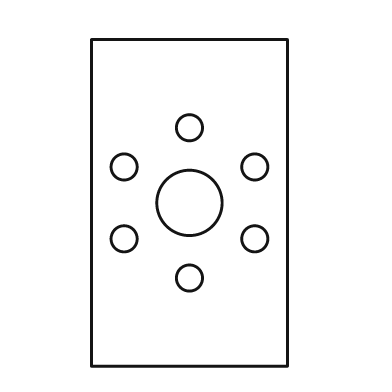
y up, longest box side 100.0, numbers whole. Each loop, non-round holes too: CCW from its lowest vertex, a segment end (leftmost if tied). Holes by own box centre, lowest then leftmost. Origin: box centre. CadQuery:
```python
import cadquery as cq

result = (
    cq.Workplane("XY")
    .moveTo(-30.0, -50.0)
    .lineTo(30.0, -50.0)
    .lineTo(30.0, 50.0)
    .lineTo(-30.0, 50.0)
    .close()
    .moveTo(0.0, -23.0)
    .circle(4.0)
    .moveTo(-20.0, -11.0)
    .circle(4.0)
    .moveTo(20.0, -11.0)
    .circle(4.0)
    .moveTo(0.0, 0.0)
    .circle(10.0)
    .moveTo(-20.0, 11.0)
    .circle(4.0)
    .moveTo(20.0, 11.0)
    .circle(4.0)
    .moveTo(0.0, 23.0)
    .circle(4.0)
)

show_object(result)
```